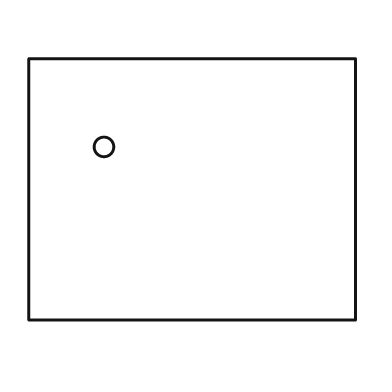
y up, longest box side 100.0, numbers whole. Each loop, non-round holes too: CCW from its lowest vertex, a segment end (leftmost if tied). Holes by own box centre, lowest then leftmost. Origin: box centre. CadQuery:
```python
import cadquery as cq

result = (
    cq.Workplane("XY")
    .moveTo(-50.0, -40.0)
    .lineTo(50.0, -40.0)
    .lineTo(50.0, 40.0)
    .lineTo(-50.0, 40.0)
    .close()
    .moveTo(-27.0, 13.0)
    .circle(3.0)
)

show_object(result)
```